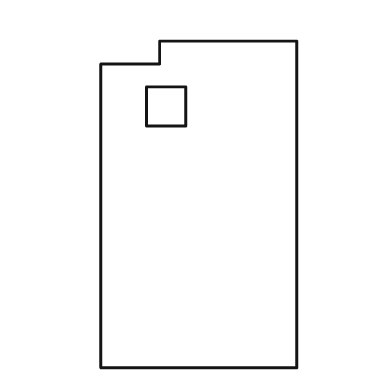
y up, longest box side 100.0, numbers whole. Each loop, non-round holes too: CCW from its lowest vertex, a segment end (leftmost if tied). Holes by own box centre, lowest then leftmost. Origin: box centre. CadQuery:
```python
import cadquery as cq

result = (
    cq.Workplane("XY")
    .moveTo(-30.0, -50.0)
    .lineTo(30.0, -50.0)
    .lineTo(30.0, 50.0)
    .lineTo(-12.0, 50.0)
    .lineTo(-12.0, 43.0)
    .lineTo(-30.0, 43.0)
    .close()
    .moveTo(-16.0, 24.0)
    .lineTo(-4.0, 24.0)
    .lineTo(-4.0, 36.0)
    .lineTo(-16.0, 36.0)
    .close()
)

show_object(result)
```